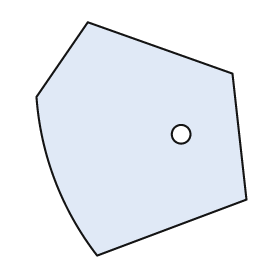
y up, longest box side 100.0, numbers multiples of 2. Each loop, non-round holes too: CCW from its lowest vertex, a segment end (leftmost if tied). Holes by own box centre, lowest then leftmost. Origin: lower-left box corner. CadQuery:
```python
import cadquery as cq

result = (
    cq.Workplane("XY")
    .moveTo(26.0, 0.0)
    .lineTo(90.0, 24.0)
    .lineTo(84.0, 78.0)
    .lineTo(22.0, 100.0)
    .lineTo(0.0, 68.0)
    .threePointArc((8.0, 32.0), (26.0, 0.0))
    .close()
    .moveTo(62.0, 52.0)
    .circle(4.0)
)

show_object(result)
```